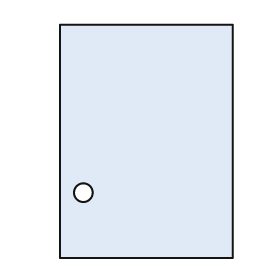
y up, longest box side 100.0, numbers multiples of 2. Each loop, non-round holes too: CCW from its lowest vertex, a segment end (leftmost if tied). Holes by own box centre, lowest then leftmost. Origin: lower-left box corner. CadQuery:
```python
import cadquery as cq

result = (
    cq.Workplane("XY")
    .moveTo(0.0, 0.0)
    .lineTo(74.0, 0.0)
    .lineTo(74.0, 100.0)
    .lineTo(0.0, 100.0)
    .close()
    .moveTo(10.0, 28.0)
    .circle(4.0)
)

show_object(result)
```